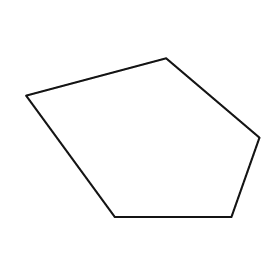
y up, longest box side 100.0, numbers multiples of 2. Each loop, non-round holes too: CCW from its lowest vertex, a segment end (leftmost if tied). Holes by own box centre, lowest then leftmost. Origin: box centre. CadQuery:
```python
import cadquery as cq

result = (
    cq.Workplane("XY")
    .moveTo(-12.0, -34.0)
    .lineTo(38.0, -34.0)
    .lineTo(50.0, 0.0)
    .lineTo(10.0, 34.0)
    .lineTo(-50.0, 18.0)
    .close()
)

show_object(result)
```